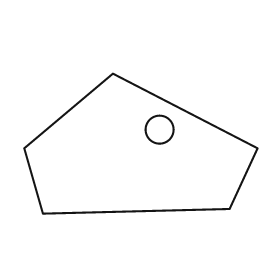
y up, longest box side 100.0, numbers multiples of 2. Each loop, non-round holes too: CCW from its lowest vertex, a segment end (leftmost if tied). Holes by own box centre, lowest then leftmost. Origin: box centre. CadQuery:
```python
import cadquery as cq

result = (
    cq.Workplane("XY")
    .moveTo(-42.0, -30.0)
    .lineTo(38.0, -28.0)
    .lineTo(50.0, -2.0)
    .lineTo(-12.0, 30.0)
    .lineTo(-50.0, -2.0)
    .close()
    .moveTo(8.0, 6.0)
    .circle(6.0)
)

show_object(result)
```